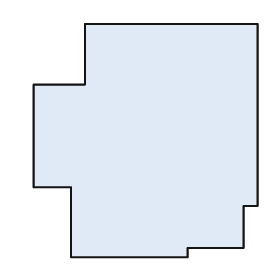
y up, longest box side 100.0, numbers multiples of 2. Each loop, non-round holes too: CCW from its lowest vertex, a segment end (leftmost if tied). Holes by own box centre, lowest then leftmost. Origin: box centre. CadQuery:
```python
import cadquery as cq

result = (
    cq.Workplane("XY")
    .moveTo(-32.0, -50.0)
    .lineTo(18.0, -50.0)
    .lineTo(18.0, -46.0)
    .lineTo(42.0, -46.0)
    .lineTo(42.0, -28.0)
    .lineTo(48.0, -28.0)
    .lineTo(48.0, 50.0)
    .lineTo(-26.0, 50.0)
    .lineTo(-26.0, 24.0)
    .lineTo(-48.0, 24.0)
    .lineTo(-48.0, -20.0)
    .lineTo(-32.0, -20.0)
    .close()
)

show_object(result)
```